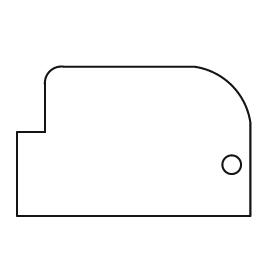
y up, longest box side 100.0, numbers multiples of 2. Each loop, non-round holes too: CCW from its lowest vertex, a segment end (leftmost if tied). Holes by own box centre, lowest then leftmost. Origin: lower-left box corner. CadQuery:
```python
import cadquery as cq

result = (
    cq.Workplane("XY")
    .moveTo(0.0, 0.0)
    .lineTo(100.0, 0.0)
    .lineTo(100.0, 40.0)
    .threePointArc((92.0, 56.0), (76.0, 64.0))
    .lineTo(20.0, 64.0)
    .threePointArc((14.0, 62.0), (12.0, 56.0))
    .lineTo(12.0, 36.0)
    .lineTo(0.0, 36.0)
    .close()
    .moveTo(92.0, 22.0)
    .circle(4.0)
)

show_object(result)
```